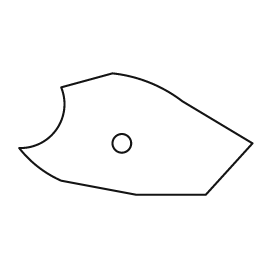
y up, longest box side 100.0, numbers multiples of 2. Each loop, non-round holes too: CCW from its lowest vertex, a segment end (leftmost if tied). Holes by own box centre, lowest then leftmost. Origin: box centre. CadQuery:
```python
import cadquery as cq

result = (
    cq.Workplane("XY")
    .moveTo(0.0, -26.0)
    .lineTo(30.0, -26.0)
    .lineTo(50.0, -4.0)
    .lineTo(20.0, 14.0)
    .threePointArc((6.0, 22.0), (-10.0, 26.0))
    .lineTo(-32.0, 20.0)
    .threePointArc((-34.0, 2.0), (-50.0, -6.0))
    .threePointArc((-42.0, -14.0), (-32.0, -20.0))
    .close()
    .moveTo(-6.0, -4.0)
    .circle(4.0)
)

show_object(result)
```